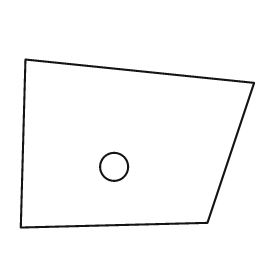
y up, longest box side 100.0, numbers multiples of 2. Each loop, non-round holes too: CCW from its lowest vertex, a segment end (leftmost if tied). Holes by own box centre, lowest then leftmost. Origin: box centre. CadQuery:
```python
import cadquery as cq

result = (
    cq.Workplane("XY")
    .moveTo(-50.0, -36.0)
    .lineTo(30.0, -34.0)
    .lineTo(50.0, 26.0)
    .lineTo(-48.0, 36.0)
    .close()
    .moveTo(-10.0, -10.0)
    .circle(6.0)
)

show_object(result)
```